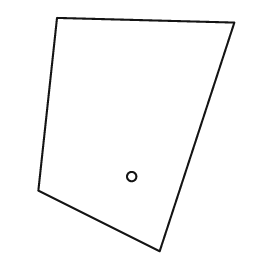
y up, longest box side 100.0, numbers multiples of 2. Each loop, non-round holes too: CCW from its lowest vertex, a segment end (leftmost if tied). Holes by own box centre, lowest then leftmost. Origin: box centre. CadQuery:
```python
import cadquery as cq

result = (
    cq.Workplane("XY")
    .moveTo(10.0, -50.0)
    .lineTo(42.0, 48.0)
    .lineTo(-34.0, 50.0)
    .lineTo(-42.0, -24.0)
    .close()
    .moveTo(-2.0, -18.0)
    .circle(2.0)
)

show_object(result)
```